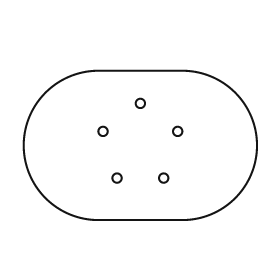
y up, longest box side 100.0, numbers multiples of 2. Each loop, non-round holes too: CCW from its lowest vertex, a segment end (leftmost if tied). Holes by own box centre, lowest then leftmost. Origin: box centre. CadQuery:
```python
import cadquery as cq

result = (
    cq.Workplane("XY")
    .moveTo(-18.0, -32.0)
    .lineTo(18.0, -32.0)
    .threePointArc((50.0, 0.0), (18.0, 32.0))
    .lineTo(-18.0, 32.0)
    .threePointArc((-50.0, 0.0), (-18.0, -32.0))
    .close()
    .moveTo(-10.0, -14.0)
    .circle(2.0)
    .moveTo(10.0, -14.0)
    .circle(2.0)
    .moveTo(-16.0, 6.0)
    .circle(2.0)
    .moveTo(16.0, 6.0)
    .circle(2.0)
    .moveTo(0.0, 18.0)
    .circle(2.0)
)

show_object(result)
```